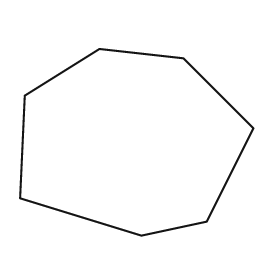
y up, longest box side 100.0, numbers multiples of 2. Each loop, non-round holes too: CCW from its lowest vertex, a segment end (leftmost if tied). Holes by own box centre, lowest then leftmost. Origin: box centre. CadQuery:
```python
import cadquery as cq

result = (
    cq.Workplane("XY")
    .moveTo(2.0, -40.0)
    .lineTo(30.0, -34.0)
    .lineTo(50.0, 6.0)
    .lineTo(20.0, 36.0)
    .lineTo(-16.0, 40.0)
    .lineTo(-48.0, 20.0)
    .lineTo(-50.0, -24.0)
    .close()
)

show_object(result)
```